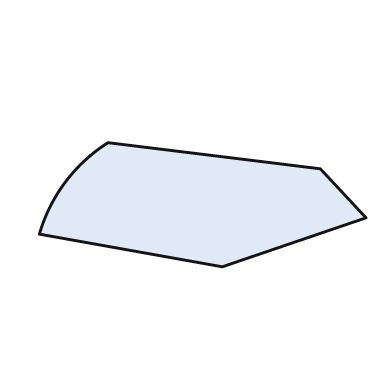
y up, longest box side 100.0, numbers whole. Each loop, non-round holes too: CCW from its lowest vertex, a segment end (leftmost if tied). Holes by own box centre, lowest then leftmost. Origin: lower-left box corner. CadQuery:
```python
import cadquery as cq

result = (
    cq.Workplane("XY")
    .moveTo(56.0, 0.0)
    .lineTo(100.0, 15.0)
    .lineTo(86.0, 30.0)
    .lineTo(21.0, 38.0)
    .threePointArc((8.0, 26.0), (0.0, 10.0))
    .close()
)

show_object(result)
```